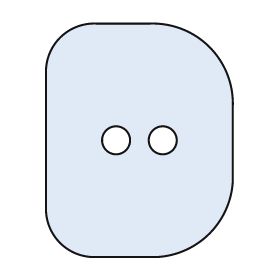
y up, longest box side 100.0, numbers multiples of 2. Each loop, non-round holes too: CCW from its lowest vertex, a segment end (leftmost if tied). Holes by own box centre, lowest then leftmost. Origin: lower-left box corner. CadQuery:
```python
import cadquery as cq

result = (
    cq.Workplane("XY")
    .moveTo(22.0, 0.0)
    .lineTo(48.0, 0.0)
    .threePointArc((70.0, 10.0), (80.0, 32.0))
    .lineTo(80.0, 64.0)
    .threePointArc((70.0, 90.0), (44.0, 100.0))
    .lineTo(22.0, 100.0)
    .threePointArc((6.0, 94.0), (0.0, 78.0))
    .lineTo(0.0, 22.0)
    .threePointArc((6.0, 6.0), (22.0, 0.0))
    .close()
    .moveTo(30.0, 50.0)
    .circle(6.0)
    .moveTo(50.0, 50.0)
    .circle(6.0)
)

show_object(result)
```